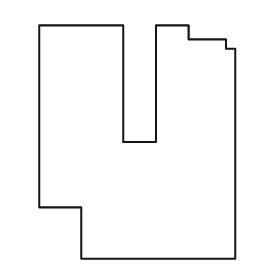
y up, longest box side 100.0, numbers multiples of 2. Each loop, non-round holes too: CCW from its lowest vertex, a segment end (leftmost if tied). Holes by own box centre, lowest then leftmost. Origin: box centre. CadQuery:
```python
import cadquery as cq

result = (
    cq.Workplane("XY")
    .moveTo(-24.0, -50.0)
    .lineTo(42.0, -50.0)
    .lineTo(42.0, 40.0)
    .lineTo(38.0, 40.0)
    .lineTo(38.0, 44.0)
    .lineTo(22.0, 44.0)
    .lineTo(22.0, 50.0)
    .lineTo(8.0, 50.0)
    .lineTo(8.0, 0.0)
    .lineTo(-6.0, 0.0)
    .lineTo(-6.0, 50.0)
    .lineTo(-42.0, 50.0)
    .lineTo(-42.0, -28.0)
    .lineTo(-24.0, -28.0)
    .close()
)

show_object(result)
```